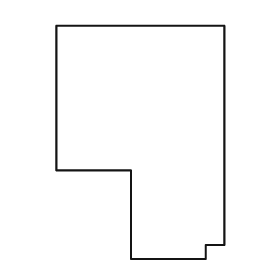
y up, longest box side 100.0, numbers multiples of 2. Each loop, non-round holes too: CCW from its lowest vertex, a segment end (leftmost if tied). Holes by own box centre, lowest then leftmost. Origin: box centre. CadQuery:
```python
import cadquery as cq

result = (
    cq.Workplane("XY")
    .moveTo(-4.0, -50.0)
    .lineTo(28.0, -50.0)
    .lineTo(28.0, -44.0)
    .lineTo(36.0, -44.0)
    .lineTo(36.0, 50.0)
    .lineTo(-36.0, 50.0)
    .lineTo(-36.0, -12.0)
    .lineTo(-4.0, -12.0)
    .close()
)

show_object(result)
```